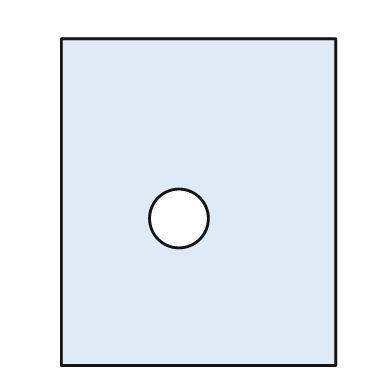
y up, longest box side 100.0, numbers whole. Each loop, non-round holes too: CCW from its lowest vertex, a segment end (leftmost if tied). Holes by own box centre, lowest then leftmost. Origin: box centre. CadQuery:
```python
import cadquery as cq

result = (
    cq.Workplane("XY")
    .moveTo(-42.0, -50.0)
    .lineTo(42.0, -50.0)
    .lineTo(42.0, 50.0)
    .lineTo(-42.0, 50.0)
    .close()
    .moveTo(-6.0, -5.0)
    .circle(9.0)
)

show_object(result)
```